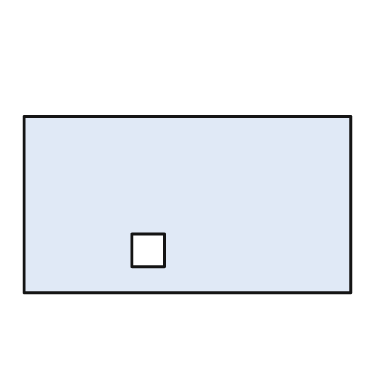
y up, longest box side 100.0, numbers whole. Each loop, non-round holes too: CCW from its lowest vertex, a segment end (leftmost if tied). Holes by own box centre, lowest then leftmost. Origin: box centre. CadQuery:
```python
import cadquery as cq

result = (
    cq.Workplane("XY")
    .moveTo(-50.0, -27.0)
    .lineTo(50.0, -27.0)
    .lineTo(50.0, 27.0)
    .lineTo(-50.0, 27.0)
    .close()
    .moveTo(-17.0, -19.0)
    .lineTo(-7.0, -19.0)
    .lineTo(-7.0, -9.0)
    .lineTo(-17.0, -9.0)
    .close()
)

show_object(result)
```